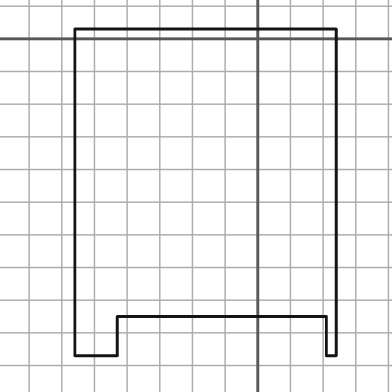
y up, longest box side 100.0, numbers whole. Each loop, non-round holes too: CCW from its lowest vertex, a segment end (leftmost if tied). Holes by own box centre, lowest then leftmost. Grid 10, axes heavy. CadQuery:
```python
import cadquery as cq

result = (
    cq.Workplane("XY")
    .moveTo(-56.0, -97.0)
    .lineTo(-43.0, -97.0)
    .lineTo(-43.0, -85.0)
    .lineTo(21.0, -85.0)
    .lineTo(21.0, -97.0)
    .lineTo(24.0, -97.0)
    .lineTo(24.0, 3.0)
    .lineTo(-56.0, 3.0)
    .close()
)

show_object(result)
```